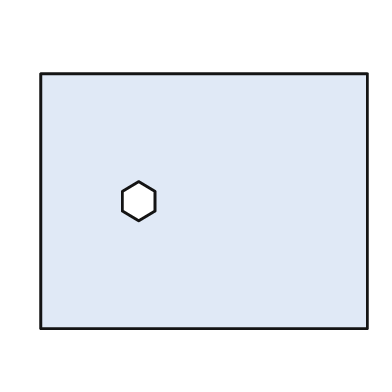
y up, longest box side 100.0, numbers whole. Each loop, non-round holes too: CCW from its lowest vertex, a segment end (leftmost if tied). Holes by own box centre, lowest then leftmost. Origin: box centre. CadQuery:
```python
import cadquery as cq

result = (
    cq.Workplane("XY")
    .moveTo(-50.0, -39.0)
    .lineTo(50.0, -39.0)
    .lineTo(50.0, 39.0)
    .lineTo(-50.0, 39.0)
    .close()
    .moveTo(-20.0, -6.0)
    .lineTo(-15.0, -3.0)
    .lineTo(-15.0, 3.0)
    .lineTo(-20.0, 6.0)
    .lineTo(-25.0, 3.0)
    .lineTo(-25.0, -3.0)
    .close()
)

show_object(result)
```